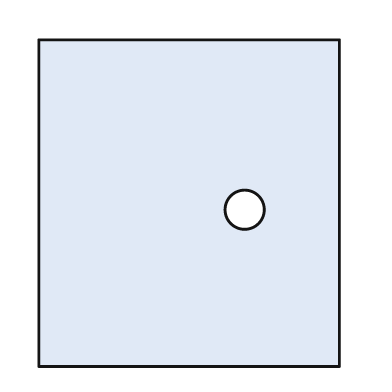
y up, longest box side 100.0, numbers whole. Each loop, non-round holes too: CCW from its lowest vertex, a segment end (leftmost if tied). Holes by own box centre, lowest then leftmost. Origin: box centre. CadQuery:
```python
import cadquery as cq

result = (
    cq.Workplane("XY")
    .moveTo(-46.0, -50.0)
    .lineTo(46.0, -50.0)
    .lineTo(46.0, 50.0)
    .lineTo(-46.0, 50.0)
    .close()
    .moveTo(17.0, -2.0)
    .circle(6.0)
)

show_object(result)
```